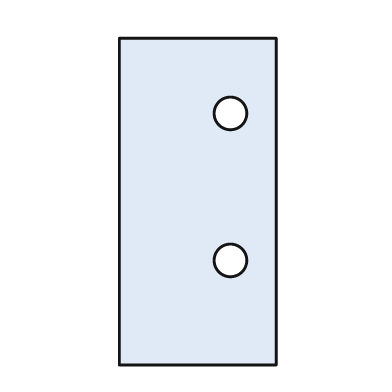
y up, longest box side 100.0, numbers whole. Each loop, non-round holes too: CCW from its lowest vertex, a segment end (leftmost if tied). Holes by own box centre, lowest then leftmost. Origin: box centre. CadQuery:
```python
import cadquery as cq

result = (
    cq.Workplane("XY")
    .moveTo(-24.0, -50.0)
    .lineTo(24.0, -50.0)
    .lineTo(24.0, 50.0)
    .lineTo(-24.0, 50.0)
    .close()
    .moveTo(10.0, -18.0)
    .circle(5.0)
    .moveTo(10.0, 27.0)
    .circle(5.0)
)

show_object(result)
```